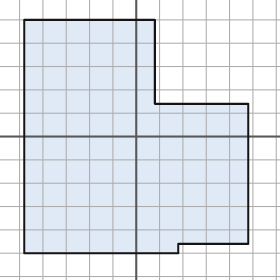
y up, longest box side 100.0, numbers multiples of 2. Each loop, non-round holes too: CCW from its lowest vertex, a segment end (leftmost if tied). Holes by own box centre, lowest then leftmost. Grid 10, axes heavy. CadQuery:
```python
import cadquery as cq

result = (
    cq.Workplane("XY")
    .moveTo(-48.0, -50.0)
    .lineTo(18.0, -50.0)
    .lineTo(18.0, -46.0)
    .lineTo(48.0, -46.0)
    .lineTo(48.0, 14.0)
    .lineTo(8.0, 14.0)
    .lineTo(8.0, 50.0)
    .lineTo(-48.0, 50.0)
    .close()
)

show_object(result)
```